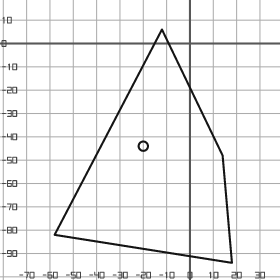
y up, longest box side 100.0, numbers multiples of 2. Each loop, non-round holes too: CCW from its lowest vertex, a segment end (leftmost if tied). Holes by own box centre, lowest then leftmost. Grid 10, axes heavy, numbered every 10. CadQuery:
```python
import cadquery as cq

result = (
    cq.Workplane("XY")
    .moveTo(18.0, -94.0)
    .lineTo(14.0, -48.0)
    .lineTo(-12.0, 6.0)
    .lineTo(-58.0, -82.0)
    .close()
    .moveTo(-20.0, -44.0)
    .circle(2.0)
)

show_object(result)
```